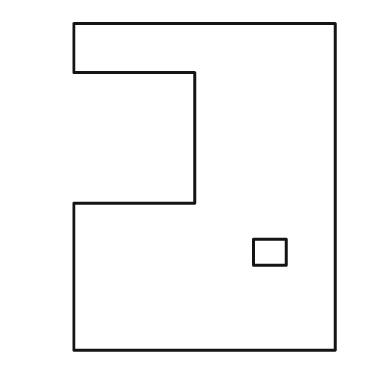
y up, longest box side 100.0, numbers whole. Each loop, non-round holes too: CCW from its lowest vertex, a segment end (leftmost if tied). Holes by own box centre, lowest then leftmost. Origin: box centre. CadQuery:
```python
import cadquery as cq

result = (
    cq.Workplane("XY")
    .moveTo(-40.0, -50.0)
    .lineTo(40.0, -50.0)
    .lineTo(40.0, 50.0)
    .lineTo(-40.0, 50.0)
    .lineTo(-40.0, 35.0)
    .lineTo(-3.0, 35.0)
    .lineTo(-3.0, -5.0)
    .lineTo(-40.0, -5.0)
    .close()
    .moveTo(15.0, -24.0)
    .lineTo(25.0, -24.0)
    .lineTo(25.0, -16.0)
    .lineTo(15.0, -16.0)
    .close()
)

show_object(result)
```